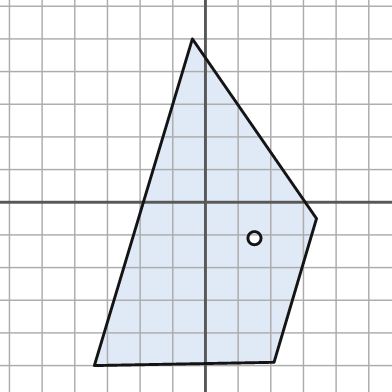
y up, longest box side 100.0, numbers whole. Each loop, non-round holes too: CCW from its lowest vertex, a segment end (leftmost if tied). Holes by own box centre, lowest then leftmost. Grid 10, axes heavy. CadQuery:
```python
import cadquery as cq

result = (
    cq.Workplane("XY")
    .moveTo(-34.0, -50.0)
    .lineTo(21.0, -49.0)
    .lineTo(34.0, -5.0)
    .lineTo(-4.0, 50.0)
    .close()
    .moveTo(15.0, -11.0)
    .circle(2.0)
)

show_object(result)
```